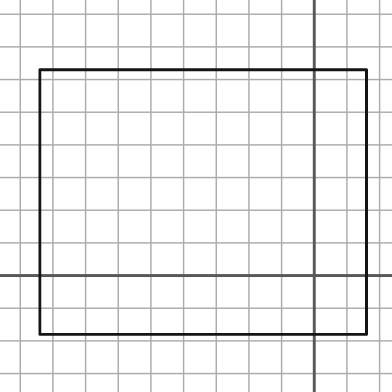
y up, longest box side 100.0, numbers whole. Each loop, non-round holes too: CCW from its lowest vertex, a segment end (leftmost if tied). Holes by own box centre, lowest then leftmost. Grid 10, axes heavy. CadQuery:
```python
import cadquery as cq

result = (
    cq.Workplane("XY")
    .moveTo(-84.0, -18.0)
    .lineTo(16.0, -18.0)
    .lineTo(16.0, 63.0)
    .lineTo(-84.0, 63.0)
    .close()
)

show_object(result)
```